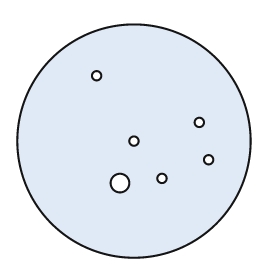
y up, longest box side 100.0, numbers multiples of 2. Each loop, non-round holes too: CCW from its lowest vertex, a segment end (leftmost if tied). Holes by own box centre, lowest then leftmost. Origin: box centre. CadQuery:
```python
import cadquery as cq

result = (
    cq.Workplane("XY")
    .moveTo(0.0, 0.0)
    .circle(50.0)
    .moveTo(-6.0, -18.0)
    .circle(4.0)
    .moveTo(12.0, -16.0)
    .circle(2.0)
    .moveTo(32.0, -8.0)
    .circle(2.0)
    .moveTo(0.0, 0.0)
    .circle(2.0)
    .moveTo(28.0, 8.0)
    .circle(2.0)
    .moveTo(-16.0, 28.0)
    .circle(2.0)
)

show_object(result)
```